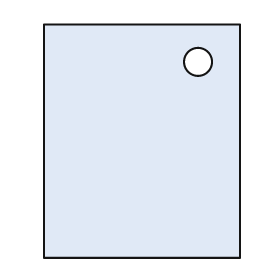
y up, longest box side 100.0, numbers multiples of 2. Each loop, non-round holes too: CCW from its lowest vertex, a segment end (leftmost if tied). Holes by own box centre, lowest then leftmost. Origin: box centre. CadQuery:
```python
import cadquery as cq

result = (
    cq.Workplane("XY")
    .moveTo(-42.0, -50.0)
    .lineTo(42.0, -50.0)
    .lineTo(42.0, 50.0)
    .lineTo(-42.0, 50.0)
    .close()
    .moveTo(24.0, 34.0)
    .circle(6.0)
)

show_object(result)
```